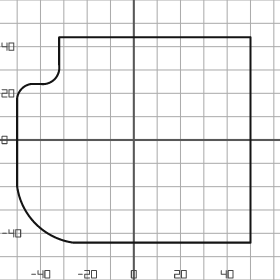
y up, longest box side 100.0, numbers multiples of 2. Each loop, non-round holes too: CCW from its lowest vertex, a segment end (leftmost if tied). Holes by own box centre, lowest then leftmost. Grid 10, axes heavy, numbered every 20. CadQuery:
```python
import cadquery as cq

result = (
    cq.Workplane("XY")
    .moveTo(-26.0, -44.0)
    .lineTo(50.0, -44.0)
    .lineTo(50.0, 44.0)
    .lineTo(-32.0, 44.0)
    .lineTo(-32.0, 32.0)
    .threePointArc((-34.0, 26.0), (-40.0, 24.0))
    .lineTo(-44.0, 24.0)
    .threePointArc((-48.0, 22.0), (-50.0, 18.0))
    .lineTo(-50.0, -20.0)
    .threePointArc((-42.0, -36.0), (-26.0, -44.0))
    .close()
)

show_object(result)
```